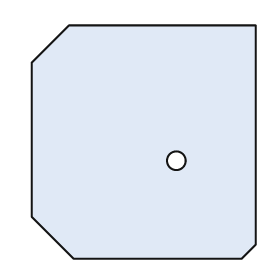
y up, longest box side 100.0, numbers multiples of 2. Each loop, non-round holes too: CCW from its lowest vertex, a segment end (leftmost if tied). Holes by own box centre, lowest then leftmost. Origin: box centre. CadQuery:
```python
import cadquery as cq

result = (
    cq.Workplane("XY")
    .moveTo(-30.0, -50.0)
    .lineTo(42.0, -50.0)
    .lineTo(48.0, -44.0)
    .lineTo(48.0, 50.0)
    .lineTo(-32.0, 50.0)
    .lineTo(-48.0, 34.0)
    .lineTo(-48.0, -32.0)
    .close()
    .moveTo(14.0, -8.0)
    .circle(4.0)
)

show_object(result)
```